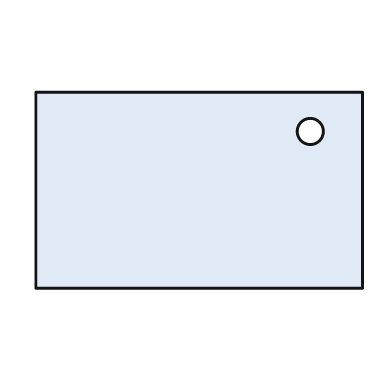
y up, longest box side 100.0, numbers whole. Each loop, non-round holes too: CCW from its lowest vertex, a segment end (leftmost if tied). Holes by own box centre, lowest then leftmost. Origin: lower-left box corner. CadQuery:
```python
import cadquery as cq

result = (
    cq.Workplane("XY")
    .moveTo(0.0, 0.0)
    .lineTo(100.0, 0.0)
    .lineTo(100.0, 60.0)
    .lineTo(0.0, 60.0)
    .close()
    .moveTo(84.0, 48.0)
    .circle(4.0)
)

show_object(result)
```